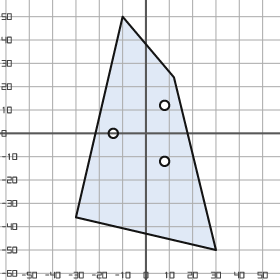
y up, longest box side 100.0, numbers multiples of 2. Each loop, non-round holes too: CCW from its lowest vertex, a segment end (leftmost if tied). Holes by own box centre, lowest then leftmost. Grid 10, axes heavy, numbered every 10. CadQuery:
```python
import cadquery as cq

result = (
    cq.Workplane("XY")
    .moveTo(30.0, -50.0)
    .lineTo(12.0, 24.0)
    .lineTo(-10.0, 50.0)
    .lineTo(-30.0, -36.0)
    .close()
    .moveTo(8.0, -12.0)
    .circle(2.0)
    .moveTo(-14.0, 0.0)
    .circle(2.0)
    .moveTo(8.0, 12.0)
    .circle(2.0)
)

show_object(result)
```